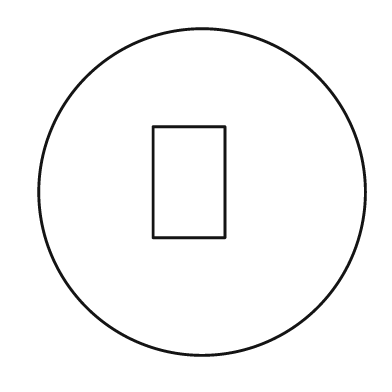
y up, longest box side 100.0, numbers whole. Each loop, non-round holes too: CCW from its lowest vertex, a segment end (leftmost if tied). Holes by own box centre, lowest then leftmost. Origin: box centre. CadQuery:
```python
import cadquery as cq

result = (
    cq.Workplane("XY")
    .moveTo(0.0, 0.0)
    .circle(50.0)
    .moveTo(-15.0, -14.0)
    .lineTo(7.0, -14.0)
    .lineTo(7.0, 20.0)
    .lineTo(-15.0, 20.0)
    .close()
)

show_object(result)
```